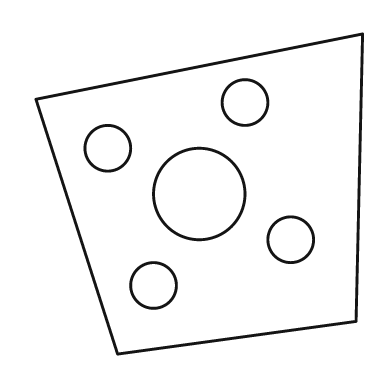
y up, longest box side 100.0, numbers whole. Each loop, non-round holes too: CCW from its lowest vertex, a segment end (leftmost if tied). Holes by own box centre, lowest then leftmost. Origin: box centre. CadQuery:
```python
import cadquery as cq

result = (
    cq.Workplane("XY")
    .moveTo(-25.0, -49.0)
    .lineTo(48.0, -39.0)
    .lineTo(50.0, 49.0)
    .lineTo(-50.0, 29.0)
    .close()
    .moveTo(-14.0, -28.0)
    .circle(7.0)
    .moveTo(28.0, -14.0)
    .circle(7.0)
    .moveTo(0.0, 0.0)
    .circle(14.0)
    .moveTo(-28.0, 14.0)
    .circle(7.0)
    .moveTo(14.0, 28.0)
    .circle(7.0)
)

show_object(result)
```